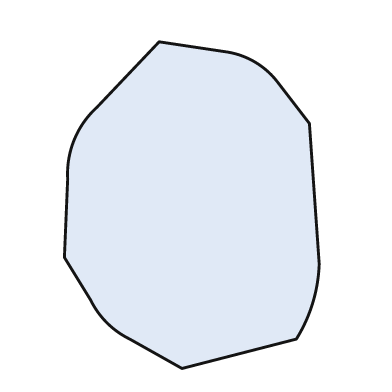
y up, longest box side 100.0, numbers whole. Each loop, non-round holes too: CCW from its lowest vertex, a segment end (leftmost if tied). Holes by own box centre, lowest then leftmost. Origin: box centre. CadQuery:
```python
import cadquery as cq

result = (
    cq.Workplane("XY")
    .moveTo(-3.0, -50.0)
    .lineTo(32.0, -41.0)
    .threePointArc((37.0, -30.0), (39.0, -18.0))
    .lineTo(36.0, 25.0)
    .lineTo(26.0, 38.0)
    .threePointArc((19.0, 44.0), (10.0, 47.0))
    .lineTo(-10.0, 50.0)
    .lineTo(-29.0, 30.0)
    .threePointArc((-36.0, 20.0), (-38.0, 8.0))
    .lineTo(-39.0, -16.0)
    .lineTo(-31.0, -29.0)
    .threePointArc((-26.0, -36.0), (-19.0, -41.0))
    .close()
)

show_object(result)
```